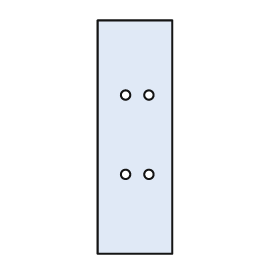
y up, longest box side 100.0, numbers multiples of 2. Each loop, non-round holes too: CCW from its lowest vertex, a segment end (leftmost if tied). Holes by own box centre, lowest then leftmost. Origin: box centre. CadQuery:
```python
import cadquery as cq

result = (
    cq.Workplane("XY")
    .moveTo(-16.0, -50.0)
    .lineTo(16.0, -50.0)
    .lineTo(16.0, 50.0)
    .lineTo(-16.0, 50.0)
    .close()
    .moveTo(-4.0, -16.0)
    .circle(2.0)
    .moveTo(6.0, -16.0)
    .circle(2.0)
    .moveTo(-4.0, 18.0)
    .circle(2.0)
    .moveTo(6.0, 18.0)
    .circle(2.0)
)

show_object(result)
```